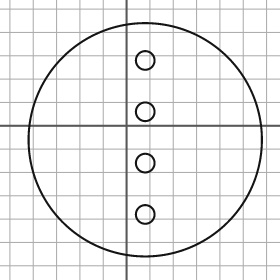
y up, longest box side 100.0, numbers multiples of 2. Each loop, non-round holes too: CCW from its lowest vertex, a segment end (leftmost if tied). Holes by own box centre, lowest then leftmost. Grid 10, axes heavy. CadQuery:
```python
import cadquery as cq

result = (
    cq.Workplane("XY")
    .moveTo(8.0, -6.0)
    .circle(50.0)
    .moveTo(8.0, -38.0)
    .circle(4.0)
    .moveTo(8.0, -16.0)
    .circle(4.0)
    .moveTo(8.0, 6.0)
    .circle(4.0)
    .moveTo(8.0, 28.0)
    .circle(4.0)
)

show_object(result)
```